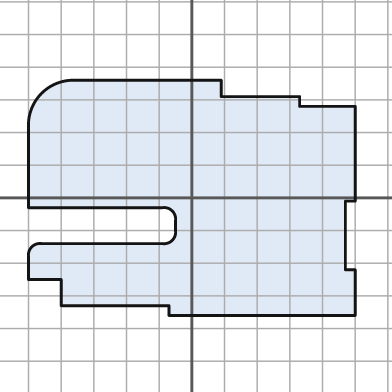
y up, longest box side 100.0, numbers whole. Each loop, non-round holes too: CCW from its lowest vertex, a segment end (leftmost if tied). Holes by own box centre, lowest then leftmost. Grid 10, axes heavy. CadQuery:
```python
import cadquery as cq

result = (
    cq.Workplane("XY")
    .moveTo(-7.0, -36.0)
    .lineTo(50.0, -36.0)
    .lineTo(50.0, -22.0)
    .lineTo(47.0, -22.0)
    .lineTo(47.0, -1.0)
    .lineTo(50.0, -1.0)
    .lineTo(50.0, 28.0)
    .lineTo(33.0, 28.0)
    .lineTo(33.0, 31.0)
    .lineTo(9.0, 31.0)
    .lineTo(9.0, 36.0)
    .lineTo(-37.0, 36.0)
    .threePointArc((-46.0, 32.0), (-50.0, 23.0))
    .lineTo(-50.0, -3.0)
    .lineTo(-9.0, -3.0)
    .threePointArc((-6.0, -4.0), (-5.0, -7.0))
    .lineTo(-5.0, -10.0)
    .threePointArc((-6.0, -13.0), (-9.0, -14.0))
    .lineTo(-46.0, -14.0)
    .threePointArc((-49.0, -15.0), (-50.0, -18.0))
    .lineTo(-50.0, -25.0)
    .lineTo(-40.0, -25.0)
    .lineTo(-40.0, -33.0)
    .lineTo(-7.0, -33.0)
    .close()
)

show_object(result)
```